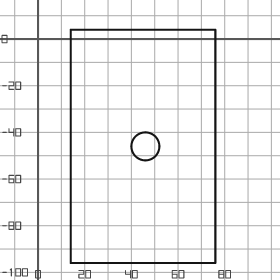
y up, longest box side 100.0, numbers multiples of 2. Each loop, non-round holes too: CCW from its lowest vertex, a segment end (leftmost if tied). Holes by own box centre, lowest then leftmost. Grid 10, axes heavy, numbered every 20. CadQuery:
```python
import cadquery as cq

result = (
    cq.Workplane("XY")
    .moveTo(14.0, -96.0)
    .lineTo(76.0, -96.0)
    .lineTo(76.0, 4.0)
    .lineTo(14.0, 4.0)
    .close()
    .moveTo(46.0, -46.0)
    .circle(6.0)
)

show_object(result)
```